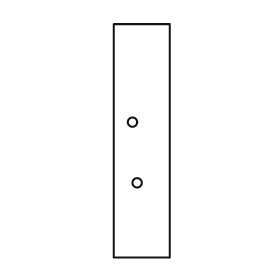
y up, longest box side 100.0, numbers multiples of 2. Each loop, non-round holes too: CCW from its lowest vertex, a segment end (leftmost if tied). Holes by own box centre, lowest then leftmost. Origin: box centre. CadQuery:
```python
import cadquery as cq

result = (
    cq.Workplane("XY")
    .moveTo(-12.0, -50.0)
    .lineTo(12.0, -50.0)
    .lineTo(12.0, 50.0)
    .lineTo(-12.0, 50.0)
    .close()
    .moveTo(-2.0, -18.0)
    .circle(2.0)
    .moveTo(-4.0, 8.0)
    .circle(2.0)
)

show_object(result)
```